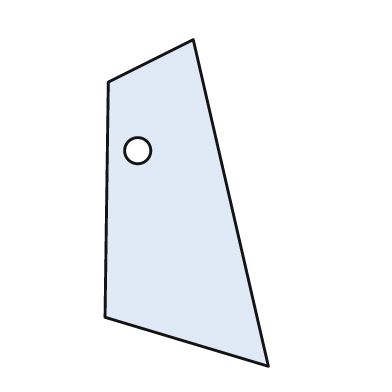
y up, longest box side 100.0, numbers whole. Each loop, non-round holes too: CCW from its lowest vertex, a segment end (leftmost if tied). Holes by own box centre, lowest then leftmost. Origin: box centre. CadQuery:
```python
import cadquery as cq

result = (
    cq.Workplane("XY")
    .moveTo(25.0, -50.0)
    .lineTo(2.0, 50.0)
    .lineTo(-24.0, 37.0)
    .lineTo(-25.0, -35.0)
    .close()
    .moveTo(-15.0, 16.0)
    .circle(4.0)
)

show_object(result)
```